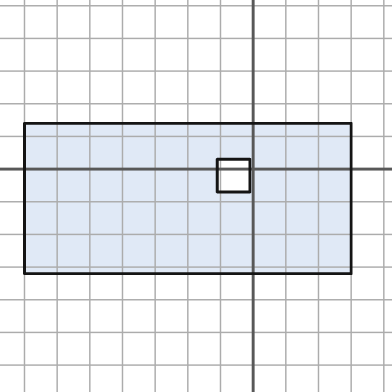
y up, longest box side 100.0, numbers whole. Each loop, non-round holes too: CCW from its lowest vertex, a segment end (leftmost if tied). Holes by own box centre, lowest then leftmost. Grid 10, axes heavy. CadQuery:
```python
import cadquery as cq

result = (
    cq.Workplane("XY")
    .moveTo(-70.0, -32.0)
    .lineTo(30.0, -32.0)
    .lineTo(30.0, 14.0)
    .lineTo(-70.0, 14.0)
    .close()
    .moveTo(-11.0, -7.0)
    .lineTo(-1.0, -7.0)
    .lineTo(-1.0, 3.0)
    .lineTo(-11.0, 3.0)
    .close()
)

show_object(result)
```